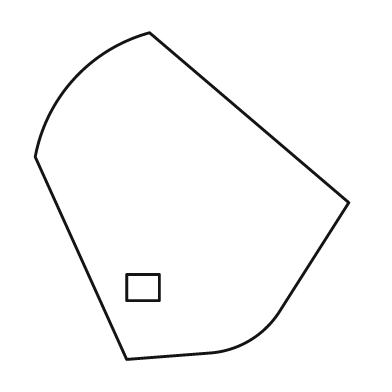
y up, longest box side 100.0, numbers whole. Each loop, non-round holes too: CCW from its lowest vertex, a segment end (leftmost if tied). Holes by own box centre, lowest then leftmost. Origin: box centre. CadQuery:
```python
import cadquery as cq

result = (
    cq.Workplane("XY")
    .moveTo(-20.0, -50.0)
    .lineTo(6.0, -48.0)
    .threePointArc((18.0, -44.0), (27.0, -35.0))
    .lineTo(48.0, -2.0)
    .lineTo(-13.0, 50.0)
    .threePointArc((-36.0, 36.0), (-48.0, 12.0))
    .close()
    .moveTo(-20.0, -32.0)
    .lineTo(-10.0, -32.0)
    .lineTo(-10.0, -24.0)
    .lineTo(-20.0, -24.0)
    .close()
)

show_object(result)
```